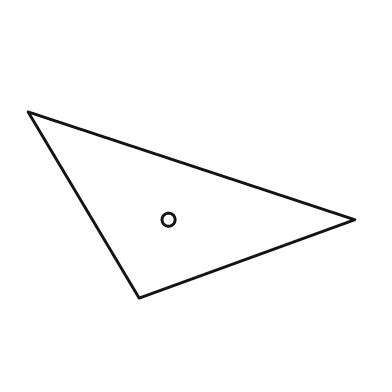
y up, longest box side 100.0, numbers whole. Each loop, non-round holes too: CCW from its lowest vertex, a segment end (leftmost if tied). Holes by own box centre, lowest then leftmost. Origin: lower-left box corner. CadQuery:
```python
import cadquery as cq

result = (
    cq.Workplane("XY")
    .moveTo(34.0, 0.0)
    .lineTo(100.0, 24.0)
    .lineTo(0.0, 57.0)
    .close()
    .moveTo(43.0, 24.0)
    .circle(2.0)
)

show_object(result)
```